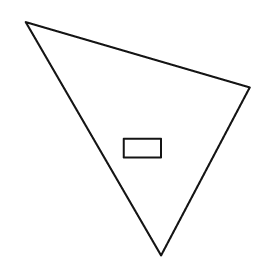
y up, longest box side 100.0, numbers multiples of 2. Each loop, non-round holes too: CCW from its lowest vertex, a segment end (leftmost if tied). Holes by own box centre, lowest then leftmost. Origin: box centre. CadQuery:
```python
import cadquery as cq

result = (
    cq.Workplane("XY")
    .moveTo(10.0, -50.0)
    .lineTo(48.0, 22.0)
    .lineTo(-48.0, 50.0)
    .close()
    .moveTo(-6.0, -8.0)
    .lineTo(10.0, -8.0)
    .lineTo(10.0, 0.0)
    .lineTo(-6.0, 0.0)
    .close()
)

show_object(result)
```